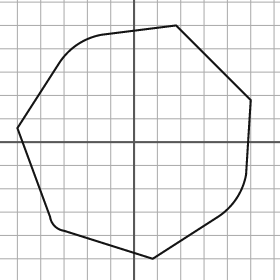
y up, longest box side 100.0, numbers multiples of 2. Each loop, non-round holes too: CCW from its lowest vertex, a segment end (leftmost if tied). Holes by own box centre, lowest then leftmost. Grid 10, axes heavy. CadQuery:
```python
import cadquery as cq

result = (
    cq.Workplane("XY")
    .moveTo(8.0, -50.0)
    .lineTo(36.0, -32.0)
    .threePointArc((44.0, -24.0), (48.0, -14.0))
    .lineTo(50.0, 18.0)
    .lineTo(18.0, 50.0)
    .lineTo(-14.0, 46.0)
    .threePointArc((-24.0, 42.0), (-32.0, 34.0))
    .lineTo(-50.0, 6.0)
    .lineTo(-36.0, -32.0)
    .threePointArc((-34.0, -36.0), (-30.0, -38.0))
    .close()
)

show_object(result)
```